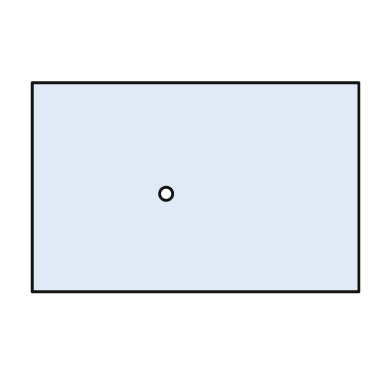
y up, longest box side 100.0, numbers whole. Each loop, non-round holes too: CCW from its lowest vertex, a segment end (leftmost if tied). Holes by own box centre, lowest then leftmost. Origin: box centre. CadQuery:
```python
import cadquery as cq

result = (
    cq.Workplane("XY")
    .moveTo(-50.0, -32.0)
    .lineTo(50.0, -32.0)
    .lineTo(50.0, 32.0)
    .lineTo(-50.0, 32.0)
    .close()
    .moveTo(-9.0, -2.0)
    .circle(2.0)
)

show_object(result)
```